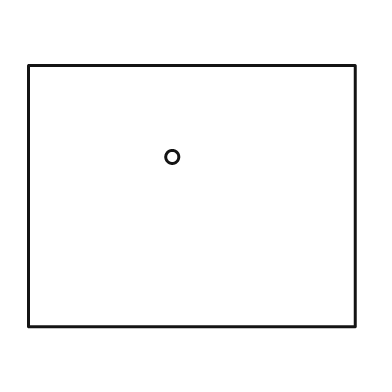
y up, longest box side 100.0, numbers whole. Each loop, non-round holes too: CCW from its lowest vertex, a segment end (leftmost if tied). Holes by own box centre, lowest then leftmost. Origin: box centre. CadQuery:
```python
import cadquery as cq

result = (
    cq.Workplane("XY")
    .moveTo(-50.0, -40.0)
    .lineTo(50.0, -40.0)
    .lineTo(50.0, 40.0)
    .lineTo(-50.0, 40.0)
    .close()
    .moveTo(-6.0, 12.0)
    .circle(2.0)
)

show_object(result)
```